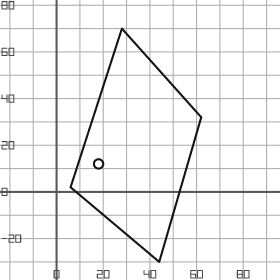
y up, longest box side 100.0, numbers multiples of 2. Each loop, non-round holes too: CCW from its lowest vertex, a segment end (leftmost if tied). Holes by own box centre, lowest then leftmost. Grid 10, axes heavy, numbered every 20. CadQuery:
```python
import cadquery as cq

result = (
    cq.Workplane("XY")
    .moveTo(44.0, -30.0)
    .lineTo(62.0, 32.0)
    .lineTo(28.0, 70.0)
    .lineTo(6.0, 2.0)
    .close()
    .moveTo(18.0, 12.0)
    .circle(2.0)
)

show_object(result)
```